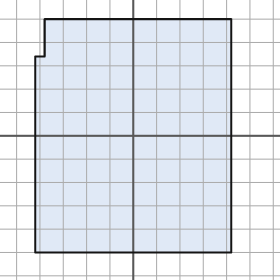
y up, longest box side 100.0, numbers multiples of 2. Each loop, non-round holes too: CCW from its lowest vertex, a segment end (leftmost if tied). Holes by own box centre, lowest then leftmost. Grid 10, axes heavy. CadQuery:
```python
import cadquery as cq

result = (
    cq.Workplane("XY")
    .moveTo(-42.0, -50.0)
    .lineTo(42.0, -50.0)
    .lineTo(42.0, 50.0)
    .lineTo(-38.0, 50.0)
    .lineTo(-38.0, 34.0)
    .lineTo(-42.0, 34.0)
    .close()
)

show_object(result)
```